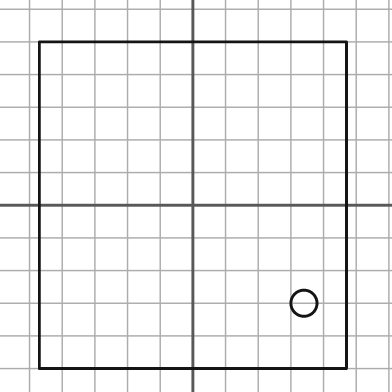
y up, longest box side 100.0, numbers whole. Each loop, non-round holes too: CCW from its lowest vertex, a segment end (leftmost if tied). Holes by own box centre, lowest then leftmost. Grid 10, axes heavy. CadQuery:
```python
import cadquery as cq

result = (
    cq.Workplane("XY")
    .moveTo(-47.0, -50.0)
    .lineTo(47.0, -50.0)
    .lineTo(47.0, 50.0)
    .lineTo(-47.0, 50.0)
    .close()
    .moveTo(34.0, -30.0)
    .circle(4.0)
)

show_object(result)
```